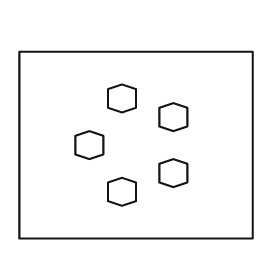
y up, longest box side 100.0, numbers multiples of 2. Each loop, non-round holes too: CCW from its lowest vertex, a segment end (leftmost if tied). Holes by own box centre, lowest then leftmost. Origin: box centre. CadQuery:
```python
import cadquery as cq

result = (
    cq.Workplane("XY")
    .moveTo(-50.0, -40.0)
    .lineTo(50.0, -40.0)
    .lineTo(50.0, 40.0)
    .lineTo(-50.0, 40.0)
    .close()
    .moveTo(-6.0, -26.0)
    .lineTo(0.0, -24.0)
    .lineTo(0.0, -16.0)
    .lineTo(-6.0, -14.0)
    .lineTo(-12.0, -16.0)
    .lineTo(-12.0, -24.0)
    .close()
    .moveTo(16.0, -18.0)
    .lineTo(22.0, -16.0)
    .lineTo(22.0, -8.0)
    .lineTo(16.0, -6.0)
    .lineTo(10.0, -8.0)
    .lineTo(10.0, -16.0)
    .close()
    .moveTo(-20.0, -6.0)
    .lineTo(-14.0, -4.0)
    .lineTo(-14.0, 4.0)
    .lineTo(-20.0, 6.0)
    .lineTo(-26.0, 4.0)
    .lineTo(-26.0, -4.0)
    .close()
    .moveTo(16.0, 6.0)
    .lineTo(22.0, 8.0)
    .lineTo(22.0, 16.0)
    .lineTo(16.0, 18.0)
    .lineTo(10.0, 16.0)
    .lineTo(10.0, 8.0)
    .close()
    .moveTo(-6.0, 14.0)
    .lineTo(0.0, 16.0)
    .lineTo(0.0, 24.0)
    .lineTo(-6.0, 26.0)
    .lineTo(-12.0, 24.0)
    .lineTo(-12.0, 16.0)
    .close()
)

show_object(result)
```